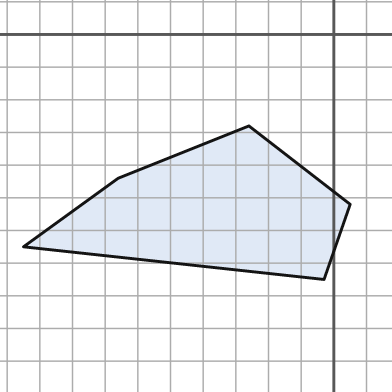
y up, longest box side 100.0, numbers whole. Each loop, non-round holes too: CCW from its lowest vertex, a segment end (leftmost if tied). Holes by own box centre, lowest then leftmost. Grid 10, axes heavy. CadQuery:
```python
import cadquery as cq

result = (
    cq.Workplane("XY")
    .moveTo(-3.0, -75.0)
    .lineTo(5.0, -52.0)
    .lineTo(-26.0, -28.0)
    .lineTo(-66.0, -44.0)
    .lineTo(-95.0, -65.0)
    .close()
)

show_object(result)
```